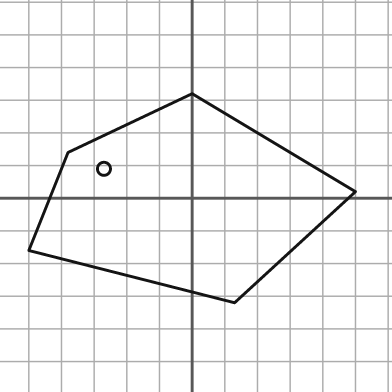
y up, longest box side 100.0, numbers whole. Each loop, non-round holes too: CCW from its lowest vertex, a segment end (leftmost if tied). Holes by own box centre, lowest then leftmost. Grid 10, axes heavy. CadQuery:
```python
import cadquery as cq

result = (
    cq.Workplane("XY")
    .moveTo(13.0, -32.0)
    .lineTo(50.0, 2.0)
    .lineTo(0.0, 32.0)
    .lineTo(-38.0, 14.0)
    .lineTo(-50.0, -16.0)
    .close()
    .moveTo(-27.0, 9.0)
    .circle(2.0)
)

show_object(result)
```